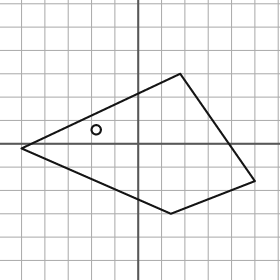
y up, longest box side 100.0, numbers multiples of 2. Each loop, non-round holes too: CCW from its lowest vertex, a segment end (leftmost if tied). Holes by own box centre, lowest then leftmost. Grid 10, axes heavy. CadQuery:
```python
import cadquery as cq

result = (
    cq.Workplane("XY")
    .moveTo(14.0, -30.0)
    .lineTo(50.0, -16.0)
    .lineTo(18.0, 30.0)
    .lineTo(-50.0, -2.0)
    .close()
    .moveTo(-18.0, 6.0)
    .circle(2.0)
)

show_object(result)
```